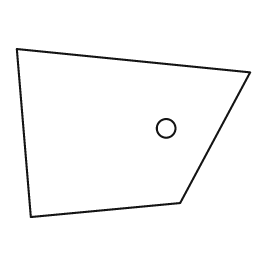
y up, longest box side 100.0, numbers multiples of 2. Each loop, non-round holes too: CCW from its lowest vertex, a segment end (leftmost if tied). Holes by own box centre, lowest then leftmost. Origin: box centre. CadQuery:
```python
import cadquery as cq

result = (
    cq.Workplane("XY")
    .moveTo(-44.0, -36.0)
    .lineTo(20.0, -30.0)
    .lineTo(50.0, 26.0)
    .lineTo(-50.0, 36.0)
    .close()
    .moveTo(14.0, 2.0)
    .circle(4.0)
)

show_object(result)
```